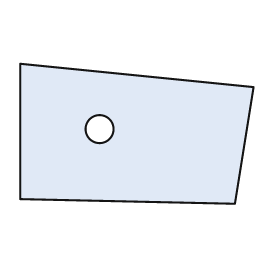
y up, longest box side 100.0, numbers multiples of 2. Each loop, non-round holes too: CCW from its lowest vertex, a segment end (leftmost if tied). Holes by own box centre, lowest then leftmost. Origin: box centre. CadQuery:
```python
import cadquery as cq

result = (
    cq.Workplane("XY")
    .moveTo(42.0, -30.0)
    .lineTo(50.0, 20.0)
    .lineTo(-50.0, 30.0)
    .lineTo(-50.0, -28.0)
    .close()
    .moveTo(-16.0, 2.0)
    .circle(6.0)
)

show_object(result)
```